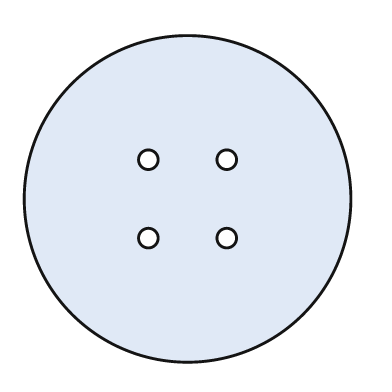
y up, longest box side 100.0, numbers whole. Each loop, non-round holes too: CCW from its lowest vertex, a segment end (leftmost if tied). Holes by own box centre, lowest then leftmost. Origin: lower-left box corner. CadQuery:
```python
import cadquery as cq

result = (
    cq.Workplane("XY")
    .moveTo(50.0, 50.0)
    .circle(50.0)
    .moveTo(38.0, 38.0)
    .circle(3.0)
    .moveTo(62.0, 38.0)
    .circle(3.0)
    .moveTo(38.0, 62.0)
    .circle(3.0)
    .moveTo(62.0, 62.0)
    .circle(3.0)
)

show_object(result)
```